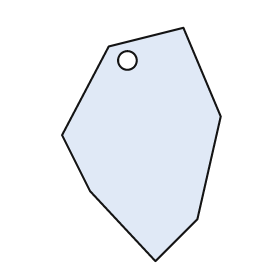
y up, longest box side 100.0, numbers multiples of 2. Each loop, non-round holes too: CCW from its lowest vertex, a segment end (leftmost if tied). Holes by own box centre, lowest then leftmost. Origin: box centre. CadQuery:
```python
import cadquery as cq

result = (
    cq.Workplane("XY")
    .moveTo(6.0, -50.0)
    .lineTo(24.0, -32.0)
    .lineTo(34.0, 12.0)
    .lineTo(18.0, 50.0)
    .lineTo(-14.0, 42.0)
    .lineTo(-34.0, 4.0)
    .lineTo(-22.0, -20.0)
    .close()
    .moveTo(-6.0, 36.0)
    .circle(4.0)
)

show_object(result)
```